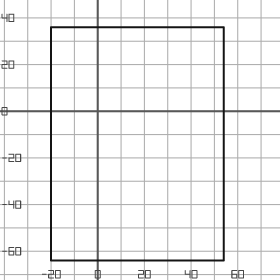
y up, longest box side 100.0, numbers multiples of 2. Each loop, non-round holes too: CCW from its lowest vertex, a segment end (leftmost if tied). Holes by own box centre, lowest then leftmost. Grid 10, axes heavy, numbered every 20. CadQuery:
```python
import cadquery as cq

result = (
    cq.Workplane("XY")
    .moveTo(-20.0, -64.0)
    .lineTo(54.0, -64.0)
    .lineTo(54.0, 36.0)
    .lineTo(-20.0, 36.0)
    .close()
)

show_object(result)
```